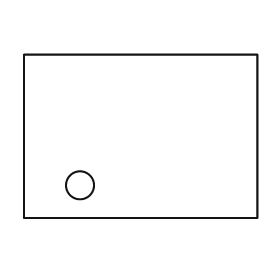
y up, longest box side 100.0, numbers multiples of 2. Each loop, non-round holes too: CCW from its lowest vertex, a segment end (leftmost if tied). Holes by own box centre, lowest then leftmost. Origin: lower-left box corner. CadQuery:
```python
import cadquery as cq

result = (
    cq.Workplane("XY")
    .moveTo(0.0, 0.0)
    .lineTo(100.0, 0.0)
    .lineTo(100.0, 70.0)
    .lineTo(0.0, 70.0)
    .close()
    .moveTo(24.0, 14.0)
    .circle(6.0)
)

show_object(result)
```